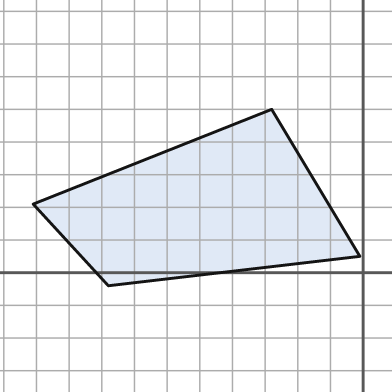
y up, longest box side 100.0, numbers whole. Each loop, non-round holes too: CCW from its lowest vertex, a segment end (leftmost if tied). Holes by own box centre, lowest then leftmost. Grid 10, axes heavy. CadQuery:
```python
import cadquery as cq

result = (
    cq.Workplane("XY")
    .moveTo(-78.0, -4.0)
    .lineTo(-1.0, 5.0)
    .lineTo(-28.0, 50.0)
    .lineTo(-101.0, 21.0)
    .close()
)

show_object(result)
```